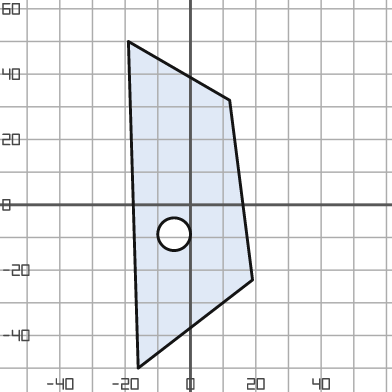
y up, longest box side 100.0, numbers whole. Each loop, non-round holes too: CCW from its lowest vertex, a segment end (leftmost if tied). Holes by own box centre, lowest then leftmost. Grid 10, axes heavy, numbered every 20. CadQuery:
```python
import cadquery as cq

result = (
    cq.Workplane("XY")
    .moveTo(-16.0, -50.0)
    .lineTo(19.0, -23.0)
    .lineTo(12.0, 32.0)
    .lineTo(-19.0, 50.0)
    .close()
    .moveTo(-5.0, -9.0)
    .circle(5.0)
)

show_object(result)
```